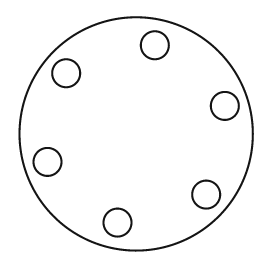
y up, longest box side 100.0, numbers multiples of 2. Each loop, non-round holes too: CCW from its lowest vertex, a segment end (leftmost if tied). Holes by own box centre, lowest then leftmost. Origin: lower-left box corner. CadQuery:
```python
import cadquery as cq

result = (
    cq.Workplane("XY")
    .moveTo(50.0, 50.0)
    .circle(50.0)
    .moveTo(42.0, 12.0)
    .circle(6.0)
    .moveTo(80.0, 24.0)
    .circle(6.0)
    .moveTo(12.0, 38.0)
    .circle(6.0)
    .moveTo(88.0, 62.0)
    .circle(6.0)
    .moveTo(20.0, 76.0)
    .circle(6.0)
    .moveTo(58.0, 88.0)
    .circle(6.0)
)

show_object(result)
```